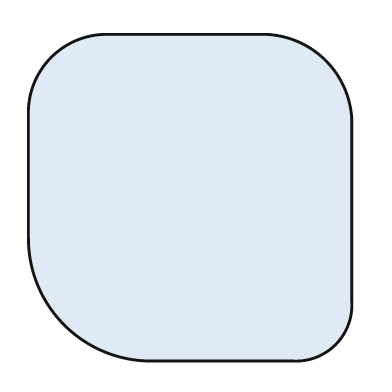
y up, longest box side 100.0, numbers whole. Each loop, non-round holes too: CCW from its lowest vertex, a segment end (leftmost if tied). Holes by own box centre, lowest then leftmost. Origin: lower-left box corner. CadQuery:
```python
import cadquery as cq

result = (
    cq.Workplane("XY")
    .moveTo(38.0, 0.0)
    .lineTo(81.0, 0.0)
    .threePointArc((94.0, 5.0), (99.0, 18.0))
    .lineTo(99.0, 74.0)
    .threePointArc((91.0, 92.0), (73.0, 100.0))
    .lineTo(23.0, 100.0)
    .threePointArc((7.0, 93.0), (0.0, 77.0))
    .lineTo(0.0, 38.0)
    .threePointArc((11.0, 11.0), (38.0, 0.0))
    .close()
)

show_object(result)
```